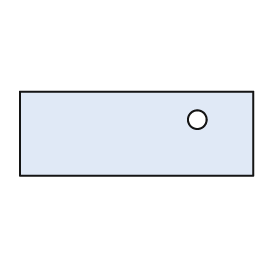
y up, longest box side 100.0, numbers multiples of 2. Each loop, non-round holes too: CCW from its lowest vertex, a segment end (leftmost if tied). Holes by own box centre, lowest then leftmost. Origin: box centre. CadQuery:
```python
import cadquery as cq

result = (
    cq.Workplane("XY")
    .moveTo(-50.0, -18.0)
    .lineTo(50.0, -18.0)
    .lineTo(50.0, 18.0)
    .lineTo(-50.0, 18.0)
    .close()
    .moveTo(26.0, 6.0)
    .circle(4.0)
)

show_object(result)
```